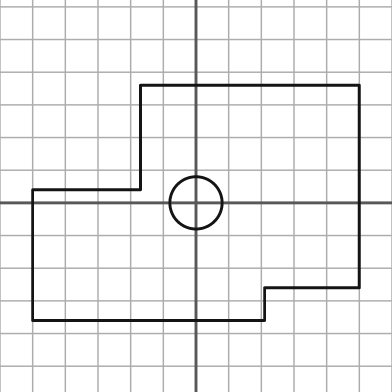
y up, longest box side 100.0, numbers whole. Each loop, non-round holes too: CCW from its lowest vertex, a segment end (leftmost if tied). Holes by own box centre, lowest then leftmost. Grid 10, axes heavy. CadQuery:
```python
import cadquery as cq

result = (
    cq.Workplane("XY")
    .moveTo(-50.0, -36.0)
    .lineTo(21.0, -36.0)
    .lineTo(21.0, -26.0)
    .lineTo(50.0, -26.0)
    .lineTo(50.0, 36.0)
    .lineTo(-17.0, 36.0)
    .lineTo(-17.0, 4.0)
    .lineTo(-50.0, 4.0)
    .close()
    .moveTo(0.0, 0.0)
    .circle(8.0)
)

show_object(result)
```